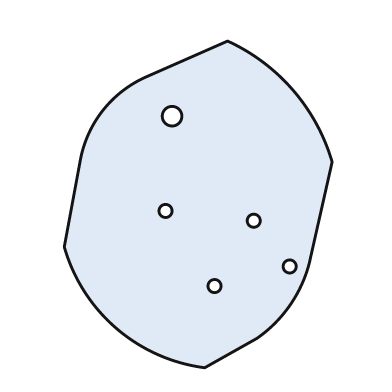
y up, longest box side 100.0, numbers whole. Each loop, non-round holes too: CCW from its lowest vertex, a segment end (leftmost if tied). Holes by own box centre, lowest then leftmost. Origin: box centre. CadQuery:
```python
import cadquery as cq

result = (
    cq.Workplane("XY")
    .moveTo(2.0, -50.0)
    .lineTo(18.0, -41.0)
    .threePointArc((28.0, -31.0), (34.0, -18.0))
    .lineTo(41.0, 13.0)
    .threePointArc((29.0, 35.0), (9.0, 50.0))
    .lineTo(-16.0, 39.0)
    .threePointArc((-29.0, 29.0), (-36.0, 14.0))
    .lineTo(-41.0, -13.0)
    .threePointArc((-25.0, -38.0), (2.0, -50.0))
    .close()
    .moveTo(5.0, -25.0)
    .circle(2.0)
    .moveTo(28.0, -19.0)
    .circle(2.0)
    .moveTo(17.0, -5.0)
    .circle(2.0)
    .moveTo(-10.0, -2.0)
    .circle(2.0)
    .moveTo(-8.0, 27.0)
    .circle(3.0)
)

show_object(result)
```